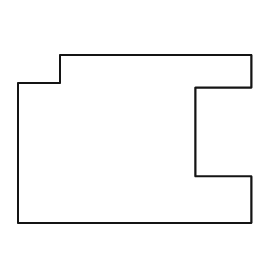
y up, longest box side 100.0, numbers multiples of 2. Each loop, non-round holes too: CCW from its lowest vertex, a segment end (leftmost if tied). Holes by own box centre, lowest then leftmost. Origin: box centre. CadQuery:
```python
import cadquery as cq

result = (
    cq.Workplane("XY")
    .moveTo(-50.0, -36.0)
    .lineTo(50.0, -36.0)
    .lineTo(50.0, -16.0)
    .lineTo(26.0, -16.0)
    .lineTo(26.0, 22.0)
    .lineTo(50.0, 22.0)
    .lineTo(50.0, 36.0)
    .lineTo(-32.0, 36.0)
    .lineTo(-32.0, 24.0)
    .lineTo(-50.0, 24.0)
    .close()
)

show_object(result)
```